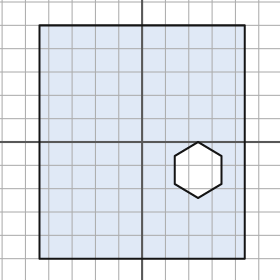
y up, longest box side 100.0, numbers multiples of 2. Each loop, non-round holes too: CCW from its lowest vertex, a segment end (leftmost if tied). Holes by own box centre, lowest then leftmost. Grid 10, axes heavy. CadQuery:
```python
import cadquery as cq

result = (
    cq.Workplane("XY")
    .moveTo(-44.0, -50.0)
    .lineTo(44.0, -50.0)
    .lineTo(44.0, 50.0)
    .lineTo(-44.0, 50.0)
    .close()
    .moveTo(24.0, -24.0)
    .lineTo(34.0, -18.0)
    .lineTo(34.0, -6.0)
    .lineTo(24.0, 0.0)
    .lineTo(14.0, -6.0)
    .lineTo(14.0, -18.0)
    .close()
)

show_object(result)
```